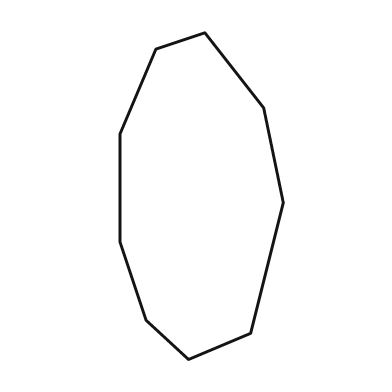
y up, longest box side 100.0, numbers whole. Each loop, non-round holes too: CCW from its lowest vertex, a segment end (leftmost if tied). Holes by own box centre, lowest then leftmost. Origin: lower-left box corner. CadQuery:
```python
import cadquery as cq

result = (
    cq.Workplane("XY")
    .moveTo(21.0, 0.0)
    .lineTo(40.0, 8.0)
    .lineTo(50.0, 48.0)
    .lineTo(44.0, 77.0)
    .lineTo(26.0, 100.0)
    .lineTo(11.0, 95.0)
    .lineTo(0.0, 69.0)
    .lineTo(0.0, 36.0)
    .lineTo(8.0, 12.0)
    .close()
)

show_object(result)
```